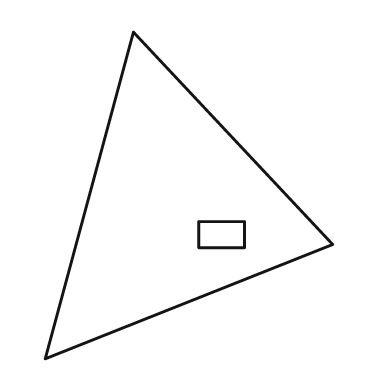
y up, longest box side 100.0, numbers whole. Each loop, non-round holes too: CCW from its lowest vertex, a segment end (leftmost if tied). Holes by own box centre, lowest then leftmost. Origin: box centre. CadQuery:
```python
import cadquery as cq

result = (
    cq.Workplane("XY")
    .moveTo(-44.0, -50.0)
    .lineTo(44.0, -15.0)
    .lineTo(-17.0, 50.0)
    .close()
    .moveTo(3.0, -16.0)
    .lineTo(17.0, -16.0)
    .lineTo(17.0, -8.0)
    .lineTo(3.0, -8.0)
    .close()
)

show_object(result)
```